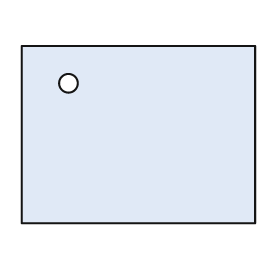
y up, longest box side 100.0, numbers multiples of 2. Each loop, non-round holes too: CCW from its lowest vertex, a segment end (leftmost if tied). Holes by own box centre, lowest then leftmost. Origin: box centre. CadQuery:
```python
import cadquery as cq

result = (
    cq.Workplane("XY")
    .moveTo(-50.0, -38.0)
    .lineTo(50.0, -38.0)
    .lineTo(50.0, 38.0)
    .lineTo(-50.0, 38.0)
    .close()
    .moveTo(-30.0, 22.0)
    .circle(4.0)
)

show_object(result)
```